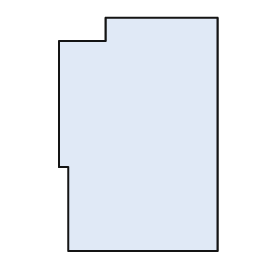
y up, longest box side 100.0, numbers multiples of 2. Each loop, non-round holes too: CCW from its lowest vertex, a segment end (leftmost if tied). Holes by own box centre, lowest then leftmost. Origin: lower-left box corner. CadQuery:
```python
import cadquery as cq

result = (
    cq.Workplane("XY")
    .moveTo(4.0, 0.0)
    .lineTo(68.0, 0.0)
    .lineTo(68.0, 100.0)
    .lineTo(20.0, 100.0)
    .lineTo(20.0, 90.0)
    .lineTo(0.0, 90.0)
    .lineTo(0.0, 36.0)
    .lineTo(4.0, 36.0)
    .close()
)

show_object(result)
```